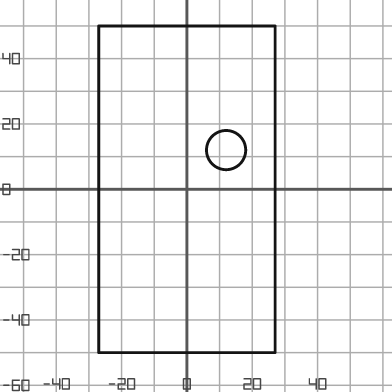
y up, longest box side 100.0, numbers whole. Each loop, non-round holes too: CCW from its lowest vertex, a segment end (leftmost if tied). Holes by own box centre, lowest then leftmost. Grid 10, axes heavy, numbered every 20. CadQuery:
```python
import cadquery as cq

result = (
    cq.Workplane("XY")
    .moveTo(-27.0, -50.0)
    .lineTo(27.0, -50.0)
    .lineTo(27.0, 50.0)
    .lineTo(-27.0, 50.0)
    .close()
    .moveTo(12.0, 12.0)
    .circle(6.0)
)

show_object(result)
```